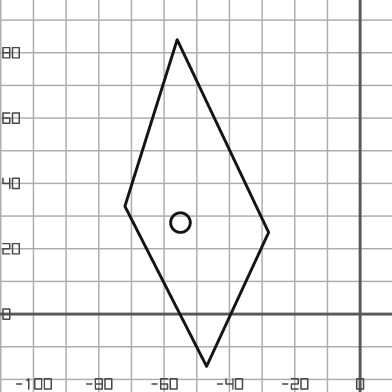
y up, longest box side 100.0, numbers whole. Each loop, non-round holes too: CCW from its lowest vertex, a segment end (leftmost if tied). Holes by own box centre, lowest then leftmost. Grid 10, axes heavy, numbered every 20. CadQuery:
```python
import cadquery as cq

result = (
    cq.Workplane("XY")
    .moveTo(-47.0, -16.0)
    .lineTo(-28.0, 25.0)
    .lineTo(-56.0, 84.0)
    .lineTo(-72.0, 33.0)
    .close()
    .moveTo(-55.0, 28.0)
    .circle(3.0)
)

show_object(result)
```